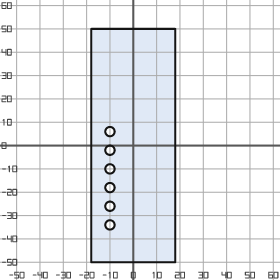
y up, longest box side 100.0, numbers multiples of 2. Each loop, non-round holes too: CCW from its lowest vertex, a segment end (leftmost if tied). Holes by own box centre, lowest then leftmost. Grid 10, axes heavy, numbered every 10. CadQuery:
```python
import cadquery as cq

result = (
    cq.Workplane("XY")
    .moveTo(-18.0, -50.0)
    .lineTo(18.0, -50.0)
    .lineTo(18.0, 50.0)
    .lineTo(-18.0, 50.0)
    .close()
    .moveTo(-10.0, -34.0)
    .circle(2.0)
    .moveTo(-10.0, -26.0)
    .circle(2.0)
    .moveTo(-10.0, -18.0)
    .circle(2.0)
    .moveTo(-10.0, -10.0)
    .circle(2.0)
    .moveTo(-10.0, -2.0)
    .circle(2.0)
    .moveTo(-10.0, 6.0)
    .circle(2.0)
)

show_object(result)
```